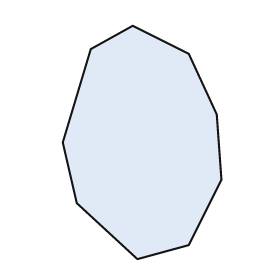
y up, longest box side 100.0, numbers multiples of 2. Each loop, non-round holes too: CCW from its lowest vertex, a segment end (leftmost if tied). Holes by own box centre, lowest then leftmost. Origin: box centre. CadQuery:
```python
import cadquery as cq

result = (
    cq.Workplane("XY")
    .moveTo(-2.0, -50.0)
    .lineTo(20.0, -44.0)
    .lineTo(34.0, -16.0)
    .lineTo(32.0, 12.0)
    .lineTo(20.0, 38.0)
    .lineTo(-4.0, 50.0)
    .lineTo(-22.0, 40.0)
    .lineTo(-34.0, 0.0)
    .lineTo(-28.0, -26.0)
    .close()
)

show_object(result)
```